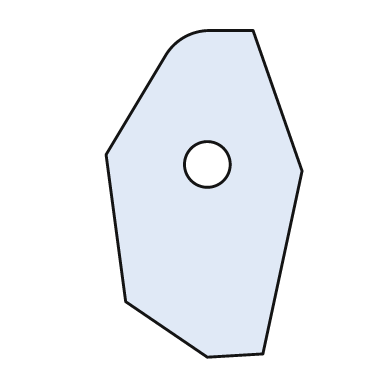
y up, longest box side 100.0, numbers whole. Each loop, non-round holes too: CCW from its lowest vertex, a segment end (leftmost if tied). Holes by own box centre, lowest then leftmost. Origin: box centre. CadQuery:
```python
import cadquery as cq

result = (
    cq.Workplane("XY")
    .moveTo(1.0, -50.0)
    .lineTo(18.0, -49.0)
    .lineTo(30.0, 7.0)
    .lineTo(15.0, 50.0)
    .lineTo(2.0, 50.0)
    .threePointArc((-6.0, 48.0), (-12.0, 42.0))
    .lineTo(-30.0, 12.0)
    .lineTo(-24.0, -33.0)
    .close()
    .moveTo(1.0, 9.0)
    .circle(7.0)
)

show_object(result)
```